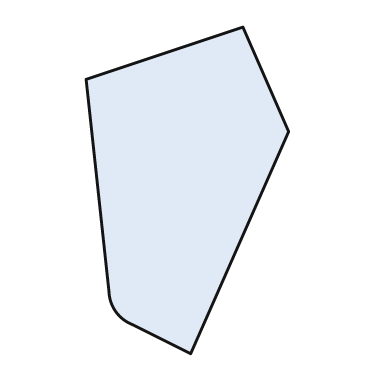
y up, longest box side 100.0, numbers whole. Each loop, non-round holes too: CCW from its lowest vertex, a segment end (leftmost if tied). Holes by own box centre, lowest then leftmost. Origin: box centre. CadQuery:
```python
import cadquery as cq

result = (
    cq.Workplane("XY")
    .moveTo(1.0, -50.0)
    .lineTo(31.0, 18.0)
    .lineTo(17.0, 50.0)
    .lineTo(-31.0, 34.0)
    .lineTo(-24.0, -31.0)
    .threePointArc((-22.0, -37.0), (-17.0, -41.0))
    .close()
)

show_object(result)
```